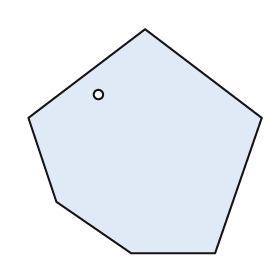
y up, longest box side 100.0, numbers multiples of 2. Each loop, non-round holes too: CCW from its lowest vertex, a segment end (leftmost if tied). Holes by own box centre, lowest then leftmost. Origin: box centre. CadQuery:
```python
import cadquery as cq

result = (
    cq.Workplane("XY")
    .moveTo(-6.0, -48.0)
    .lineTo(30.0, -48.0)
    .lineTo(50.0, 10.0)
    .lineTo(0.0, 48.0)
    .lineTo(-50.0, 10.0)
    .lineTo(-38.0, -26.0)
    .close()
    .moveTo(-20.0, 20.0)
    .circle(2.0)
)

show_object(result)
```